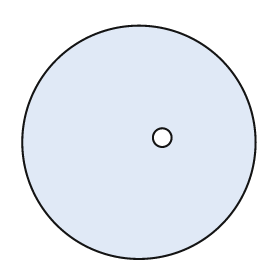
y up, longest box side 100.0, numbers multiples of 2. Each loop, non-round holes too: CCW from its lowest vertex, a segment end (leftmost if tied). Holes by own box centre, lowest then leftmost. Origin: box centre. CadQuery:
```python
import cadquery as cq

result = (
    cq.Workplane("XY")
    .moveTo(0.0, 0.0)
    .circle(50.0)
    .moveTo(10.0, 2.0)
    .circle(4.0)
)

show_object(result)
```